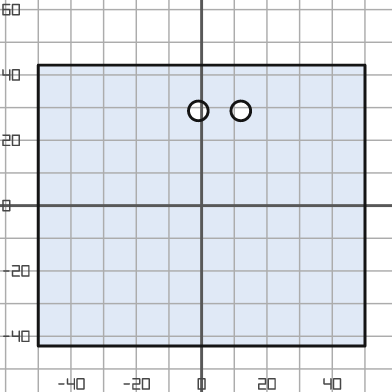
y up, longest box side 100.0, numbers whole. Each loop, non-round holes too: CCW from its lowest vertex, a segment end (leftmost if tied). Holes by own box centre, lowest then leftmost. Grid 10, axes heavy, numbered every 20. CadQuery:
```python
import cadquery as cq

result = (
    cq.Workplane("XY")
    .moveTo(-50.0, -43.0)
    .lineTo(50.0, -43.0)
    .lineTo(50.0, 43.0)
    .lineTo(-50.0, 43.0)
    .close()
    .moveTo(-1.0, 29.0)
    .circle(3.0)
    .moveTo(12.0, 29.0)
    .circle(3.0)
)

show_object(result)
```